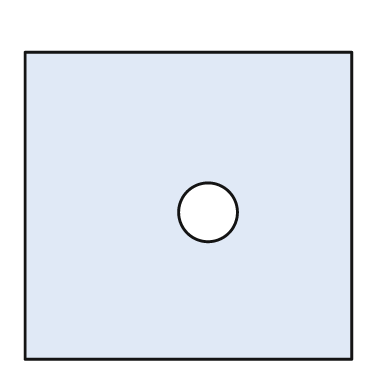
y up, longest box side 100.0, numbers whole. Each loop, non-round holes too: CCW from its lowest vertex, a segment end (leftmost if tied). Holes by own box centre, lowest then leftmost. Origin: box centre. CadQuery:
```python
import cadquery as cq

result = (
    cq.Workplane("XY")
    .moveTo(-50.0, -47.0)
    .lineTo(50.0, -47.0)
    .lineTo(50.0, 47.0)
    .lineTo(-50.0, 47.0)
    .close()
    .moveTo(6.0, -2.0)
    .circle(9.0)
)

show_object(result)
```